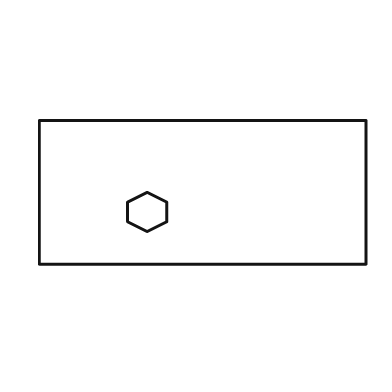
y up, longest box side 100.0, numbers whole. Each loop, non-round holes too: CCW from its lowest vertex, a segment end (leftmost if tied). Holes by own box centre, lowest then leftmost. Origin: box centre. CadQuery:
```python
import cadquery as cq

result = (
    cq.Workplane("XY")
    .moveTo(-50.0, -22.0)
    .lineTo(50.0, -22.0)
    .lineTo(50.0, 22.0)
    .lineTo(-50.0, 22.0)
    .close()
    .moveTo(-17.0, -12.0)
    .lineTo(-11.0, -9.0)
    .lineTo(-11.0, -3.0)
    .lineTo(-17.0, 0.0)
    .lineTo(-23.0, -3.0)
    .lineTo(-23.0, -9.0)
    .close()
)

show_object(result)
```